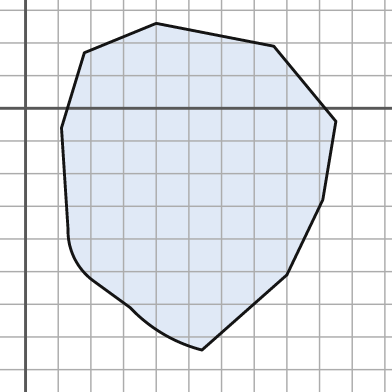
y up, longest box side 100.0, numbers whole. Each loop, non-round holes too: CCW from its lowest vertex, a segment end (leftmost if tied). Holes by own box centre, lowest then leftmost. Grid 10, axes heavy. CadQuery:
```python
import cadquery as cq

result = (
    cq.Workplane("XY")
    .moveTo(54.0, -74.0)
    .lineTo(80.0, -51.0)
    .lineTo(91.0, -28.0)
    .lineTo(95.0, -4.0)
    .lineTo(76.0, 19.0)
    .lineTo(40.0, 26.0)
    .lineTo(18.0, 17.0)
    .lineTo(11.0, -6.0)
    .lineTo(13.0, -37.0)
    .threePointArc((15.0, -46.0), (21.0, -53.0))
    .lineTo(32.0, -61.0)
    .threePointArc((42.0, -69.0), (54.0, -74.0))
    .close()
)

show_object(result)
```